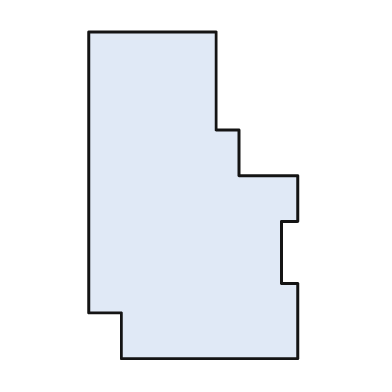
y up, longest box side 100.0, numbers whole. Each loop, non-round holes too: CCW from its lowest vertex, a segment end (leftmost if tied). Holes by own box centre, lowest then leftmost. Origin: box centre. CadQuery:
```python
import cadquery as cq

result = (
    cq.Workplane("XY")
    .moveTo(-22.0, -50.0)
    .lineTo(32.0, -50.0)
    .lineTo(32.0, -27.0)
    .lineTo(27.0, -27.0)
    .lineTo(27.0, -8.0)
    .lineTo(32.0, -8.0)
    .lineTo(32.0, 6.0)
    .lineTo(14.0, 6.0)
    .lineTo(14.0, 20.0)
    .lineTo(7.0, 20.0)
    .lineTo(7.0, 50.0)
    .lineTo(-32.0, 50.0)
    .lineTo(-32.0, -36.0)
    .lineTo(-22.0, -36.0)
    .close()
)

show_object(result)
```